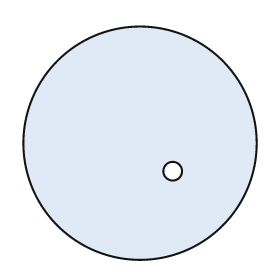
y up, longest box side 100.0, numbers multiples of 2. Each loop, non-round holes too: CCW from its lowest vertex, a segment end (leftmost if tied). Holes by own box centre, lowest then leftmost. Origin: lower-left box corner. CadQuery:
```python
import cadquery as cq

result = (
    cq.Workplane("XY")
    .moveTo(50.0, 50.0)
    .circle(50.0)
    .moveTo(64.0, 38.0)
    .circle(4.0)
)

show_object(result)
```